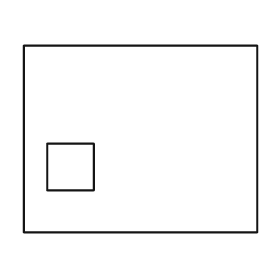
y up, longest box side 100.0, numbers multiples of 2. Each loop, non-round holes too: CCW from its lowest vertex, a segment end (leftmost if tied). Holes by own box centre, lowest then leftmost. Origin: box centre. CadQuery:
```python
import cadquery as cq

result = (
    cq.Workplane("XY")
    .moveTo(-50.0, -40.0)
    .lineTo(50.0, -40.0)
    .lineTo(50.0, 40.0)
    .lineTo(-50.0, 40.0)
    .close()
    .moveTo(-40.0, -22.0)
    .lineTo(-20.0, -22.0)
    .lineTo(-20.0, -2.0)
    .lineTo(-40.0, -2.0)
    .close()
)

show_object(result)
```